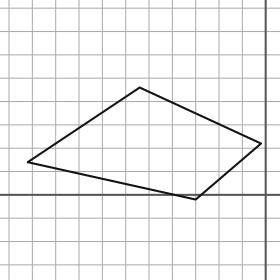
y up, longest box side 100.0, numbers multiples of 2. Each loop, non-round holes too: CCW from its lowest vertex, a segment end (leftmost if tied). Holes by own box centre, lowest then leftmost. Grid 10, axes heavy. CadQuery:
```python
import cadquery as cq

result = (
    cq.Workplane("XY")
    .moveTo(-30.0, -2.0)
    .lineTo(-2.0, 22.0)
    .lineTo(-54.0, 46.0)
    .lineTo(-102.0, 14.0)
    .close()
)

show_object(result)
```